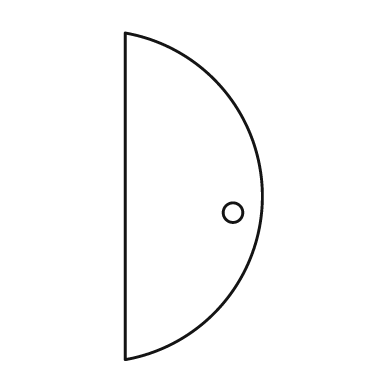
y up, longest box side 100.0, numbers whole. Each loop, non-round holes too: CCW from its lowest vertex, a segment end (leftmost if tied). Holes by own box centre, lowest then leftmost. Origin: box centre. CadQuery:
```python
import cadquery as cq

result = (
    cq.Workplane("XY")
    .moveTo(-21.0, -50.0)
    .threePointArc((21.0, 0.0), (-21.0, 50.0))
    .close()
    .moveTo(12.0, -5.0)
    .circle(3.0)
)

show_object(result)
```